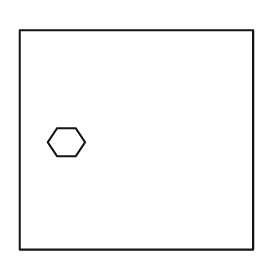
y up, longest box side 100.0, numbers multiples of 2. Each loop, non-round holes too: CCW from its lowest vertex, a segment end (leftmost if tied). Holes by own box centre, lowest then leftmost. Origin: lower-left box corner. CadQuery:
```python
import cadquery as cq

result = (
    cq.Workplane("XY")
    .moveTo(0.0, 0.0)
    .lineTo(100.0, 0.0)
    .lineTo(100.0, 94.0)
    .lineTo(0.0, 94.0)
    .close()
    .moveTo(16.0, 40.0)
    .lineTo(24.0, 40.0)
    .lineTo(28.0, 46.0)
    .lineTo(24.0, 52.0)
    .lineTo(16.0, 52.0)
    .lineTo(12.0, 46.0)
    .close()
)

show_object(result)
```